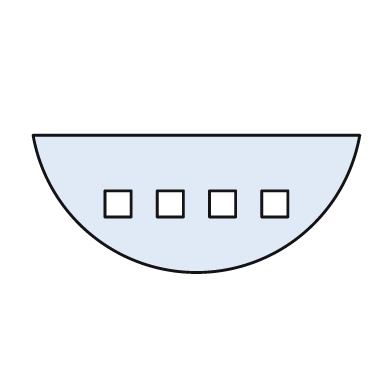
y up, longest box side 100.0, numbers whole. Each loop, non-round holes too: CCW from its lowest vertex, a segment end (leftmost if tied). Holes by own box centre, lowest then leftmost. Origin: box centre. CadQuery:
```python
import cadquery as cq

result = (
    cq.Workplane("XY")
    .moveTo(-50.0, 21.0)
    .threePointArc((0.0, -21.0), (50.0, 21.0))
    .close()
    .moveTo(-28.0, -4.0)
    .lineTo(-20.0, -4.0)
    .lineTo(-20.0, 4.0)
    .lineTo(-28.0, 4.0)
    .close()
    .moveTo(-12.0, -4.0)
    .lineTo(-4.0, -4.0)
    .lineTo(-4.0, 4.0)
    .lineTo(-12.0, 4.0)
    .close()
    .moveTo(4.0, -4.0)
    .lineTo(12.0, -4.0)
    .lineTo(12.0, 4.0)
    .lineTo(4.0, 4.0)
    .close()
    .moveTo(20.0, -4.0)
    .lineTo(28.0, -4.0)
    .lineTo(28.0, 4.0)
    .lineTo(20.0, 4.0)
    .close()
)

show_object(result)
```